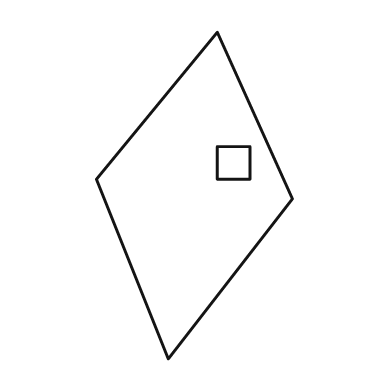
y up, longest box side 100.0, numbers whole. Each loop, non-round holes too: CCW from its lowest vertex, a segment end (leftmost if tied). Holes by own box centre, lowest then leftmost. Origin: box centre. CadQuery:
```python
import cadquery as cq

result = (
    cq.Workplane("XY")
    .moveTo(-8.0, -50.0)
    .lineTo(30.0, -1.0)
    .lineTo(7.0, 50.0)
    .lineTo(-30.0, 5.0)
    .close()
    .moveTo(7.0, 5.0)
    .lineTo(17.0, 5.0)
    .lineTo(17.0, 15.0)
    .lineTo(7.0, 15.0)
    .close()
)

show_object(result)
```